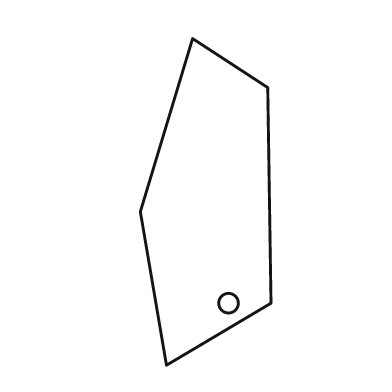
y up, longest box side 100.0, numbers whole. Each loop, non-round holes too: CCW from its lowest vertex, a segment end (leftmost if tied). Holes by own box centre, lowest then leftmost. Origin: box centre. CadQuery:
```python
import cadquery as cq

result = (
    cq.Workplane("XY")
    .moveTo(-12.0, -50.0)
    .lineTo(20.0, -31.0)
    .lineTo(19.0, 35.0)
    .lineTo(-4.0, 50.0)
    .lineTo(-20.0, -3.0)
    .close()
    .moveTo(7.0, -31.0)
    .circle(3.0)
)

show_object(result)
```